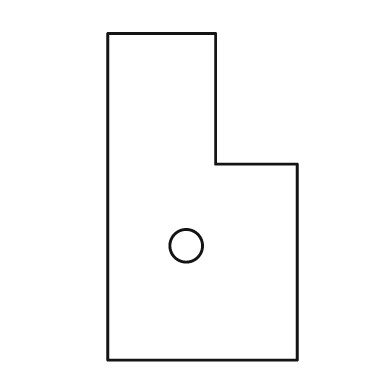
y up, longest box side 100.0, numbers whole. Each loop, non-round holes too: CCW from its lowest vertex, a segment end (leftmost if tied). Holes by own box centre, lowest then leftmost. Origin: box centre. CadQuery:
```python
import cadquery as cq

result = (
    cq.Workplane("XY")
    .moveTo(-29.0, -50.0)
    .lineTo(29.0, -50.0)
    .lineTo(29.0, 10.0)
    .lineTo(4.0, 10.0)
    .lineTo(4.0, 50.0)
    .lineTo(-29.0, 50.0)
    .close()
    .moveTo(-5.0, -15.0)
    .circle(5.0)
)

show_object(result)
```